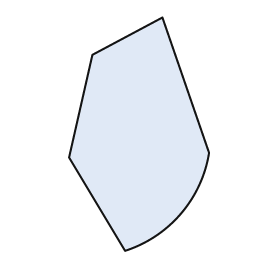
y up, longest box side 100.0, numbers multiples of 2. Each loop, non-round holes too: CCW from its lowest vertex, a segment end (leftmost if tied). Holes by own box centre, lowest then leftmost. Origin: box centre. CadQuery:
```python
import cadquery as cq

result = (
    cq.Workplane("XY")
    .moveTo(-6.0, -50.0)
    .threePointArc((18.0, -34.0), (30.0, -8.0))
    .lineTo(10.0, 50.0)
    .lineTo(-20.0, 34.0)
    .lineTo(-30.0, -10.0)
    .close()
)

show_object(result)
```